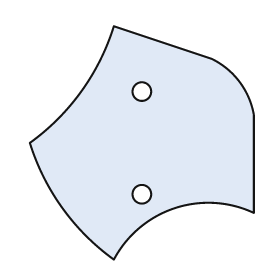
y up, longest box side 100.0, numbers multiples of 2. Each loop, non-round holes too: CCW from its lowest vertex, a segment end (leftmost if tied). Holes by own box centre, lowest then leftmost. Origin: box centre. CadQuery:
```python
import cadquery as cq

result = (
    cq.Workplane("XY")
    .moveTo(-12.0, -50.0)
    .threePointArc((14.0, -28.0), (48.0, -30.0))
    .lineTo(48.0, 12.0)
    .threePointArc((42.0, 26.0), (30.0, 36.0))
    .lineTo(-12.0, 50.0)
    .threePointArc((-26.0, 22.0), (-48.0, 0.0))
    .threePointArc((-34.0, -28.0), (-12.0, -50.0))
    .close()
    .moveTo(0.0, -22.0)
    .circle(4.0)
    .moveTo(0.0, 22.0)
    .circle(4.0)
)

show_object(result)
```